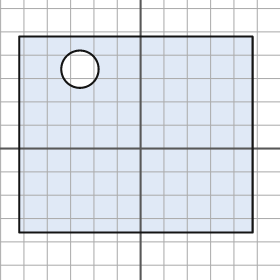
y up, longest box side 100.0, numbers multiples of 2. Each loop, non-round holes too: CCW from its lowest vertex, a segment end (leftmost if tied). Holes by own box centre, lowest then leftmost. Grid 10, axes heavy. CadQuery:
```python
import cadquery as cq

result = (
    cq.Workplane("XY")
    .moveTo(-52.0, -36.0)
    .lineTo(48.0, -36.0)
    .lineTo(48.0, 48.0)
    .lineTo(-52.0, 48.0)
    .close()
    .moveTo(-26.0, 34.0)
    .circle(8.0)
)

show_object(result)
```